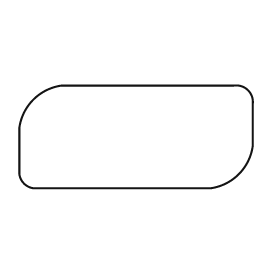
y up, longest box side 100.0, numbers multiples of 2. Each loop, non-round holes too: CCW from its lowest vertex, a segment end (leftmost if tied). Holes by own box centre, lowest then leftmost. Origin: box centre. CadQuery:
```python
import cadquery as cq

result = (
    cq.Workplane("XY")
    .moveTo(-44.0, -22.0)
    .lineTo(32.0, -22.0)
    .threePointArc((44.0, -16.0), (50.0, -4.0))
    .lineTo(50.0, 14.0)
    .threePointArc((48.0, 20.0), (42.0, 22.0))
    .lineTo(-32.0, 22.0)
    .threePointArc((-44.0, 16.0), (-50.0, 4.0))
    .lineTo(-50.0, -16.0)
    .threePointArc((-48.0, -20.0), (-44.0, -22.0))
    .close()
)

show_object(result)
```